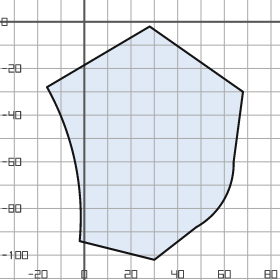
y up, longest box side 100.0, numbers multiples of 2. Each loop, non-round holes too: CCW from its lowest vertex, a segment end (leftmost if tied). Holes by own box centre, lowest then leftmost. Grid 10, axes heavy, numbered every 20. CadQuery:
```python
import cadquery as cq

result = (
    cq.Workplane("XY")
    .moveTo(30.0, -102.0)
    .lineTo(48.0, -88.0)
    .threePointArc((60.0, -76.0), (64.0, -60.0))
    .lineTo(68.0, -30.0)
    .lineTo(28.0, -2.0)
    .lineTo(-16.0, -28.0)
    .threePointArc((-4.0, -60.0), (-2.0, -94.0))
    .close()
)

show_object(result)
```